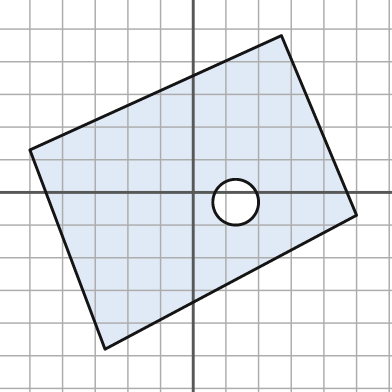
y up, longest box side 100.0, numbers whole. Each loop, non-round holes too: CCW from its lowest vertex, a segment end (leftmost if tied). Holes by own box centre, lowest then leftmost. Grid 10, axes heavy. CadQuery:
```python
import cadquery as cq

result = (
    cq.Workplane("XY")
    .moveTo(-27.0, -48.0)
    .lineTo(50.0, -7.0)
    .lineTo(27.0, 48.0)
    .lineTo(-50.0, 13.0)
    .close()
    .moveTo(13.0, -3.0)
    .circle(7.0)
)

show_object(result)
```